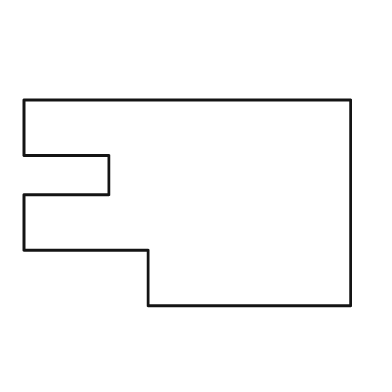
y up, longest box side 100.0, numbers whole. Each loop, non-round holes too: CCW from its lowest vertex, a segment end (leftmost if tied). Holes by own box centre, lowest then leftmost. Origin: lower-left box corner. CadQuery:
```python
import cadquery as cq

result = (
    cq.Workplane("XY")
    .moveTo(38.0, 0.0)
    .lineTo(100.0, 0.0)
    .lineTo(100.0, 63.0)
    .lineTo(0.0, 63.0)
    .lineTo(0.0, 46.0)
    .lineTo(26.0, 46.0)
    .lineTo(26.0, 34.0)
    .lineTo(0.0, 34.0)
    .lineTo(0.0, 17.0)
    .lineTo(38.0, 17.0)
    .close()
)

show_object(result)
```